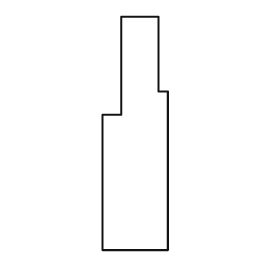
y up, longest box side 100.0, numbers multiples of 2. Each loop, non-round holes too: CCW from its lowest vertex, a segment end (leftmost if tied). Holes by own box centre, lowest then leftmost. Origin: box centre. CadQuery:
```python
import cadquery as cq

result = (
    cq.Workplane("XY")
    .moveTo(-14.0, -50.0)
    .lineTo(14.0, -50.0)
    .lineTo(14.0, 18.0)
    .lineTo(10.0, 18.0)
    .lineTo(10.0, 50.0)
    .lineTo(-6.0, 50.0)
    .lineTo(-6.0, 8.0)
    .lineTo(-14.0, 8.0)
    .close()
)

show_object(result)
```